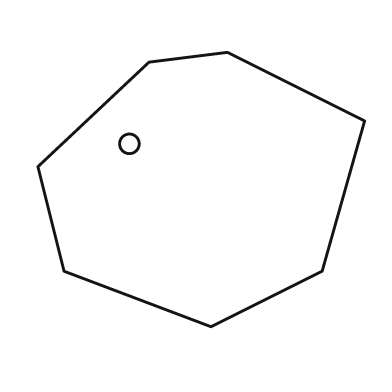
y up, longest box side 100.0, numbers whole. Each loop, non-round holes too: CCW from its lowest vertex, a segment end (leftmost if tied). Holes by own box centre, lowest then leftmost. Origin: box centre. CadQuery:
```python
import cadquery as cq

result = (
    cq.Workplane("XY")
    .moveTo(3.0, -42.0)
    .lineTo(37.0, -25.0)
    .lineTo(50.0, 21.0)
    .lineTo(8.0, 42.0)
    .lineTo(-16.0, 39.0)
    .lineTo(-50.0, 7.0)
    .lineTo(-42.0, -25.0)
    .close()
    .moveTo(-22.0, 14.0)
    .circle(3.0)
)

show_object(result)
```